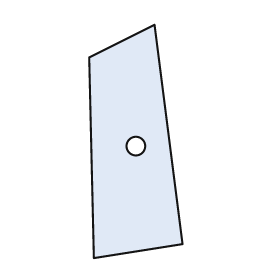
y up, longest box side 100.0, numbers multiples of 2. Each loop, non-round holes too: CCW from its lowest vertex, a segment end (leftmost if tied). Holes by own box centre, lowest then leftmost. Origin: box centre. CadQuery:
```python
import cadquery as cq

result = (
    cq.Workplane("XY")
    .moveTo(-18.0, -50.0)
    .lineTo(20.0, -44.0)
    .lineTo(8.0, 50.0)
    .lineTo(-20.0, 36.0)
    .close()
    .moveTo(0.0, -2.0)
    .circle(4.0)
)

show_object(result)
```